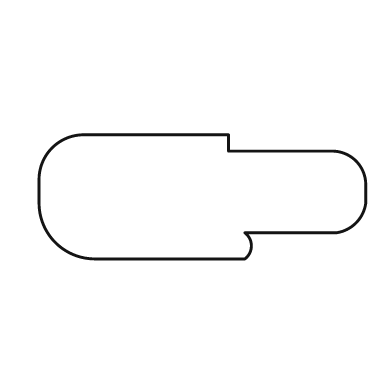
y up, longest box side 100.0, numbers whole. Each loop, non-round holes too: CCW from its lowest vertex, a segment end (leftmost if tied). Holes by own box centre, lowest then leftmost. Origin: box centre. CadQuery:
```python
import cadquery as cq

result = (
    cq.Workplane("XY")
    .moveTo(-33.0, -19.0)
    .lineTo(13.0, -19.0)
    .threePointArc((15.0, -15.0), (13.0, -11.0))
    .lineTo(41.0, -11.0)
    .threePointArc((47.0, -8.0), (50.0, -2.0))
    .lineTo(50.0, 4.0)
    .threePointArc((47.0, 11.0), (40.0, 14.0))
    .lineTo(8.0, 14.0)
    .lineTo(8.0, 19.0)
    .lineTo(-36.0, 19.0)
    .threePointArc((-46.0, 15.0), (-50.0, 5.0))
    .lineTo(-50.0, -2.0)
    .threePointArc((-45.0, -14.0), (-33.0, -19.0))
    .close()
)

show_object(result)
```